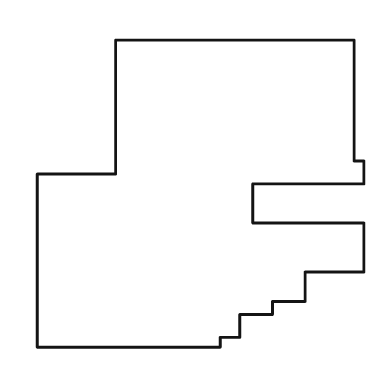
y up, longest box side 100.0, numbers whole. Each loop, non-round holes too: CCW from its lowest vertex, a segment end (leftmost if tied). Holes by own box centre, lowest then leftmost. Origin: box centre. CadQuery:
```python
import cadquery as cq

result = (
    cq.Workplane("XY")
    .moveTo(-50.0, -47.0)
    .lineTo(6.0, -47.0)
    .lineTo(6.0, -44.0)
    .lineTo(12.0, -44.0)
    .lineTo(12.0, -37.0)
    .lineTo(22.0, -37.0)
    .lineTo(22.0, -33.0)
    .lineTo(32.0, -33.0)
    .lineTo(32.0, -24.0)
    .lineTo(50.0, -24.0)
    .lineTo(50.0, -9.0)
    .lineTo(16.0, -9.0)
    .lineTo(16.0, 3.0)
    .lineTo(50.0, 3.0)
    .lineTo(50.0, 10.0)
    .lineTo(47.0, 10.0)
    .lineTo(47.0, 47.0)
    .lineTo(-26.0, 47.0)
    .lineTo(-26.0, 6.0)
    .lineTo(-50.0, 6.0)
    .close()
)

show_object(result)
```